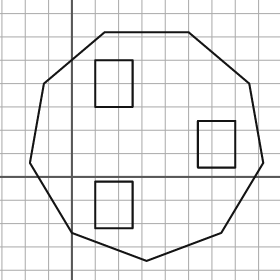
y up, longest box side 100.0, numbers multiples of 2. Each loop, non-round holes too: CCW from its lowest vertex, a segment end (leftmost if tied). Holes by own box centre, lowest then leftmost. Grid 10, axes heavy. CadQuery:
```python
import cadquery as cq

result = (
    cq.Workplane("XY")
    .moveTo(32.0, -36.0)
    .lineTo(64.0, -24.0)
    .lineTo(82.0, 6.0)
    .lineTo(76.0, 40.0)
    .lineTo(50.0, 62.0)
    .lineTo(14.0, 62.0)
    .lineTo(-12.0, 40.0)
    .lineTo(-18.0, 6.0)
    .lineTo(0.0, -24.0)
    .close()
    .moveTo(10.0, -22.0)
    .lineTo(26.0, -22.0)
    .lineTo(26.0, -2.0)
    .lineTo(10.0, -2.0)
    .close()
    .moveTo(54.0, 4.0)
    .lineTo(70.0, 4.0)
    .lineTo(70.0, 24.0)
    .lineTo(54.0, 24.0)
    .close()
    .moveTo(10.0, 30.0)
    .lineTo(26.0, 30.0)
    .lineTo(26.0, 50.0)
    .lineTo(10.0, 50.0)
    .close()
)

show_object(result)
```